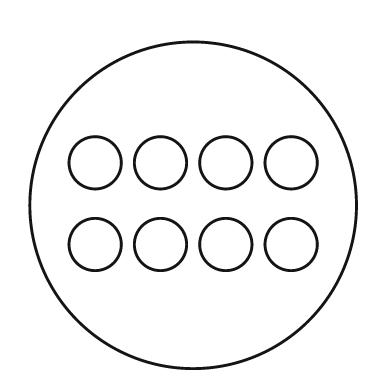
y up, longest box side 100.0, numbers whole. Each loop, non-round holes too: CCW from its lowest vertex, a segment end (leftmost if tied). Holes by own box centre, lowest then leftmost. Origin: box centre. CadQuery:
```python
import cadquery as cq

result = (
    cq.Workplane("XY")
    .moveTo(0.0, 0.0)
    .circle(50.0)
    .moveTo(-30.0, -12.0)
    .circle(8.0)
    .moveTo(-10.0, -12.0)
    .circle(8.0)
    .moveTo(10.0, -12.0)
    .circle(8.0)
    .moveTo(30.0, -12.0)
    .circle(8.0)
    .moveTo(-30.0, 13.0)
    .circle(8.0)
    .moveTo(-10.0, 13.0)
    .circle(8.0)
    .moveTo(10.0, 13.0)
    .circle(8.0)
    .moveTo(30.0, 13.0)
    .circle(8.0)
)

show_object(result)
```